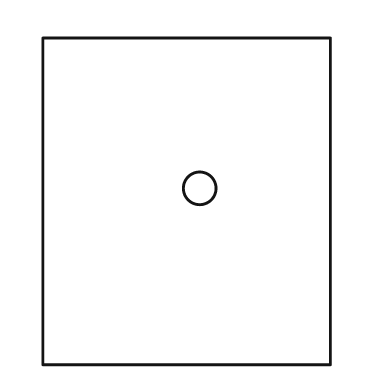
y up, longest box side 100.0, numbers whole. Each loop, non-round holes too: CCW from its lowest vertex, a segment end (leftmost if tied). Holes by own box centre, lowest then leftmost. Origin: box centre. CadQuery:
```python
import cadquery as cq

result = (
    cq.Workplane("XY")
    .moveTo(-44.0, -50.0)
    .lineTo(44.0, -50.0)
    .lineTo(44.0, 50.0)
    .lineTo(-44.0, 50.0)
    .close()
    .moveTo(4.0, 4.0)
    .circle(5.0)
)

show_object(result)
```